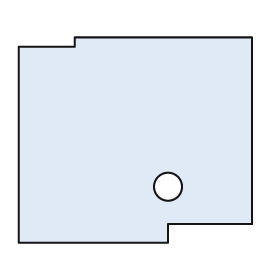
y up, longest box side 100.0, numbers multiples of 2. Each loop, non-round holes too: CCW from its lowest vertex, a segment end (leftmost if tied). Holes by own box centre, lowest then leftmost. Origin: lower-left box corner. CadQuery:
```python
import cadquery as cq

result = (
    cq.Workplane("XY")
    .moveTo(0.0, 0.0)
    .lineTo(64.0, 0.0)
    .lineTo(64.0, 8.0)
    .lineTo(100.0, 8.0)
    .lineTo(100.0, 88.0)
    .lineTo(24.0, 88.0)
    .lineTo(24.0, 84.0)
    .lineTo(0.0, 84.0)
    .close()
    .moveTo(64.0, 24.0)
    .circle(6.0)
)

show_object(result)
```